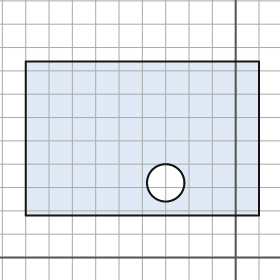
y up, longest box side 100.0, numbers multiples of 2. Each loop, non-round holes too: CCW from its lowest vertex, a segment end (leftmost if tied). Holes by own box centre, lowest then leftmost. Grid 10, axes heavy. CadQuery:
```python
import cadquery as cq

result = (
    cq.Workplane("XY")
    .moveTo(-90.0, 18.0)
    .lineTo(10.0, 18.0)
    .lineTo(10.0, 84.0)
    .lineTo(-90.0, 84.0)
    .close()
    .moveTo(-30.0, 32.0)
    .circle(8.0)
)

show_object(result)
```